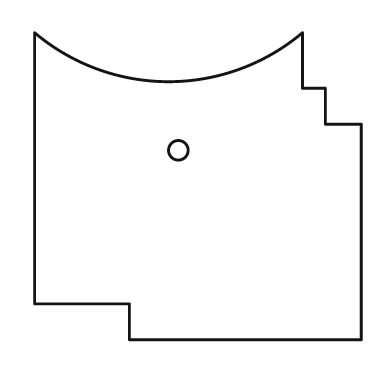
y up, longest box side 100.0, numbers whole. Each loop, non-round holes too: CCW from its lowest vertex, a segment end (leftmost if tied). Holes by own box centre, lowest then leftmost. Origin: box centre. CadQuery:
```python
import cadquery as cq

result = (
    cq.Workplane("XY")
    .moveTo(-21.0, -47.0)
    .lineTo(50.0, -47.0)
    .lineTo(50.0, 19.0)
    .lineTo(39.0, 19.0)
    .lineTo(39.0, 30.0)
    .lineTo(32.0, 30.0)
    .lineTo(32.0, 47.0)
    .threePointArc((-9.0, 32.0), (-50.0, 47.0))
    .lineTo(-50.0, -36.0)
    .lineTo(-21.0, -36.0)
    .close()
    .moveTo(-6.0, 11.0)
    .circle(3.0)
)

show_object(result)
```